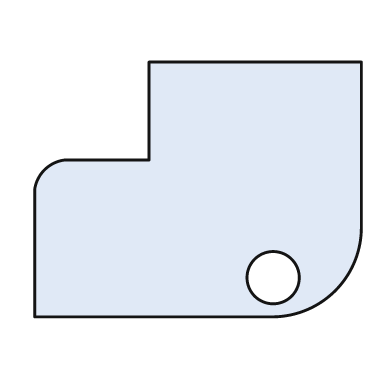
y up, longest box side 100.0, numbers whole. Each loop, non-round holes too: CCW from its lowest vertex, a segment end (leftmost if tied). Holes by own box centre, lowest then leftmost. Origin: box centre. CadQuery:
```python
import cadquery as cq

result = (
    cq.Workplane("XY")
    .moveTo(-50.0, -39.0)
    .lineTo(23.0, -39.0)
    .threePointArc((42.0, -31.0), (50.0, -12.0))
    .lineTo(50.0, 39.0)
    .lineTo(-15.0, 39.0)
    .lineTo(-15.0, 9.0)
    .lineTo(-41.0, 9.0)
    .threePointArc((-47.0, 6.0), (-50.0, 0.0))
    .close()
    .moveTo(23.0, -27.0)
    .circle(8.0)
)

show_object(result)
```